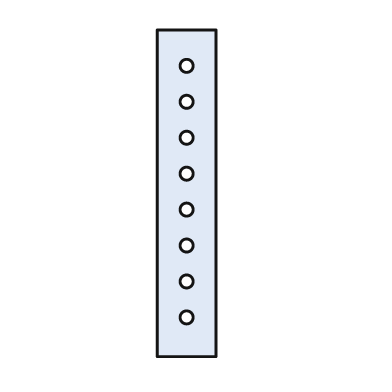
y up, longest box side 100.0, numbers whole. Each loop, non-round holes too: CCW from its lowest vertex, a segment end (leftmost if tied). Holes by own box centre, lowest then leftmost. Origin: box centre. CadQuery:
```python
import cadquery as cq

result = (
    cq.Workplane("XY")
    .moveTo(-9.0, -50.0)
    .lineTo(9.0, -50.0)
    .lineTo(9.0, 50.0)
    .lineTo(-9.0, 50.0)
    .close()
    .moveTo(0.0, -38.0)
    .circle(2.0)
    .moveTo(0.0, -27.0)
    .circle(2.0)
    .moveTo(0.0, -16.0)
    .circle(2.0)
    .moveTo(0.0, -5.0)
    .circle(2.0)
    .moveTo(0.0, 6.0)
    .circle(2.0)
    .moveTo(0.0, 17.0)
    .circle(2.0)
    .moveTo(0.0, 28.0)
    .circle(2.0)
    .moveTo(0.0, 39.0)
    .circle(2.0)
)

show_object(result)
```